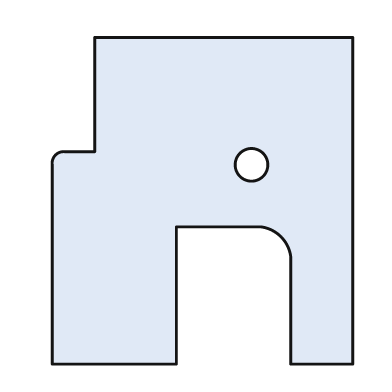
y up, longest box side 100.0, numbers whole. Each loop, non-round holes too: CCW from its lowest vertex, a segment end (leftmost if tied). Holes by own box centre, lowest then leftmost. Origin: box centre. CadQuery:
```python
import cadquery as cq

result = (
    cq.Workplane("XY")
    .moveTo(-46.0, -50.0)
    .lineTo(-8.0, -50.0)
    .lineTo(-8.0, -8.0)
    .lineTo(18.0, -8.0)
    .threePointArc((24.0, -11.0), (27.0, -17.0))
    .lineTo(27.0, -50.0)
    .lineTo(46.0, -50.0)
    .lineTo(46.0, 50.0)
    .lineTo(-33.0, 50.0)
    .lineTo(-33.0, 15.0)
    .lineTo(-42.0, 15.0)
    .threePointArc((-45.0, 14.0), (-46.0, 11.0))
    .close()
    .moveTo(15.0, 11.0)
    .circle(5.0)
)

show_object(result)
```